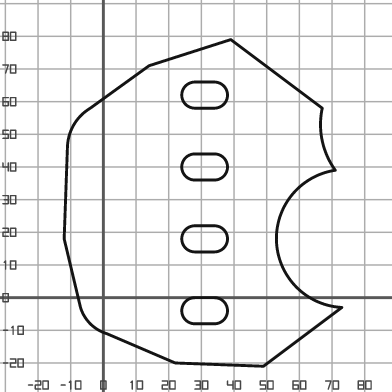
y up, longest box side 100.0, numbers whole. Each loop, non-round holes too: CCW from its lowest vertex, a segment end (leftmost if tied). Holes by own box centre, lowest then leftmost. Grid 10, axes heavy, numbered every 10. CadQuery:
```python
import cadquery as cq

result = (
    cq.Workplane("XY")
    .moveTo(49.0, -21.0)
    .lineTo(73.0, -3.0)
    .threePointArc((53.0, 17.0), (71.0, 39.0))
    .threePointArc((67.0, 48.0), (67.0, 58.0))
    .lineTo(39.0, 79.0)
    .lineTo(14.0, 71.0)
    .lineTo(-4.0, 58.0)
    .threePointArc((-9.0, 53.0), (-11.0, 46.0))
    .lineTo(-12.0, 18.0)
    .lineTo(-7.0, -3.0)
    .threePointArc((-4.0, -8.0), (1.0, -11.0))
    .lineTo(22.0, -20.0)
    .close()
    .moveTo(28.0, -8.0)
    .lineTo(34.0, -8.0)
    .threePointArc((38.0, -4.0), (34.0, 0.0))
    .lineTo(28.0, 0.0)
    .threePointArc((24.0, -4.0), (28.0, -8.0))
    .close()
    .moveTo(28.0, 14.0)
    .lineTo(34.0, 14.0)
    .threePointArc((38.0, 18.0), (34.0, 22.0))
    .lineTo(28.0, 22.0)
    .threePointArc((24.0, 18.0), (28.0, 14.0))
    .close()
    .moveTo(28.0, 36.0)
    .lineTo(34.0, 36.0)
    .threePointArc((38.0, 40.0), (34.0, 44.0))
    .lineTo(28.0, 44.0)
    .threePointArc((24.0, 40.0), (28.0, 36.0))
    .close()
    .moveTo(28.0, 58.0)
    .lineTo(34.0, 58.0)
    .threePointArc((38.0, 62.0), (34.0, 66.0))
    .lineTo(28.0, 66.0)
    .threePointArc((24.0, 62.0), (28.0, 58.0))
    .close()
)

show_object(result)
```